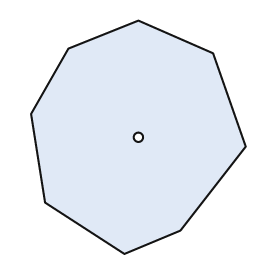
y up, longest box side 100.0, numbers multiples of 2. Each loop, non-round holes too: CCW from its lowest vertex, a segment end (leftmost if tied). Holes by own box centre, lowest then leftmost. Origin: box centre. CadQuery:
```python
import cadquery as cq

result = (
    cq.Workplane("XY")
    .moveTo(-6.0, -50.0)
    .lineTo(18.0, -40.0)
    .lineTo(46.0, -4.0)
    .lineTo(32.0, 36.0)
    .lineTo(0.0, 50.0)
    .lineTo(-30.0, 38.0)
    .lineTo(-46.0, 10.0)
    .lineTo(-40.0, -28.0)
    .close()
    .moveTo(0.0, 0.0)
    .circle(2.0)
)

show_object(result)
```